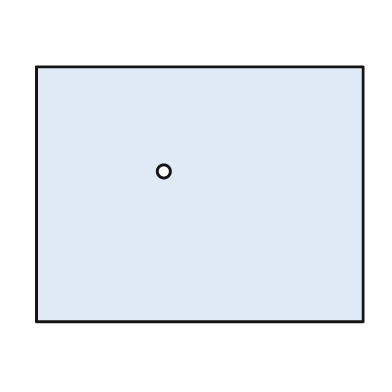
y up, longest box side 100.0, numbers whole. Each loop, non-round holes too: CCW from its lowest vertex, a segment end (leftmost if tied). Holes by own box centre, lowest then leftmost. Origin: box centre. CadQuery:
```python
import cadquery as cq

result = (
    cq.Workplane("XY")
    .moveTo(-50.0, -39.0)
    .lineTo(50.0, -39.0)
    .lineTo(50.0, 39.0)
    .lineTo(-50.0, 39.0)
    .close()
    .moveTo(-11.0, 7.0)
    .circle(2.0)
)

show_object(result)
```